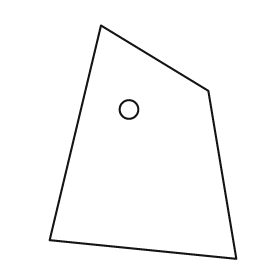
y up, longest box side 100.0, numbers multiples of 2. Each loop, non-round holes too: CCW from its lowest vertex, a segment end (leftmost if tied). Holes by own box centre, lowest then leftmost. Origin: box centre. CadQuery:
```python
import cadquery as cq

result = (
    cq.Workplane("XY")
    .moveTo(40.0, -50.0)
    .lineTo(28.0, 22.0)
    .lineTo(-18.0, 50.0)
    .lineTo(-40.0, -42.0)
    .close()
    .moveTo(-6.0, 14.0)
    .circle(4.0)
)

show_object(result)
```